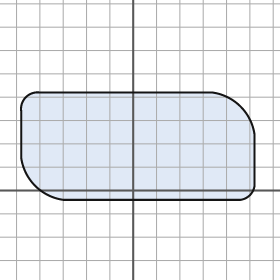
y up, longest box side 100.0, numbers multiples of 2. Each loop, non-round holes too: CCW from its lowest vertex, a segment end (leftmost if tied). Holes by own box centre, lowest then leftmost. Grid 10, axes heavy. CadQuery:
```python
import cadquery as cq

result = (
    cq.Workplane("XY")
    .moveTo(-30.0, -4.0)
    .lineTo(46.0, -4.0)
    .threePointArc((50.0, -2.0), (52.0, 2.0))
    .lineTo(52.0, 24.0)
    .threePointArc((46.0, 36.0), (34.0, 42.0))
    .lineTo(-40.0, 42.0)
    .threePointArc((-46.0, 40.0), (-48.0, 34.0))
    .lineTo(-48.0, 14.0)
    .threePointArc((-42.0, 2.0), (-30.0, -4.0))
    .close()
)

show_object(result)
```